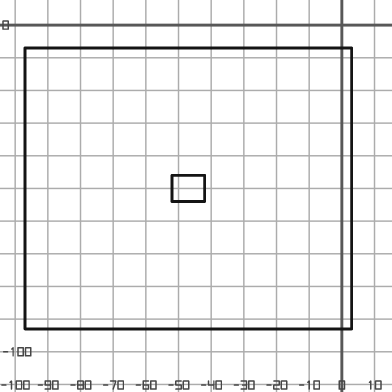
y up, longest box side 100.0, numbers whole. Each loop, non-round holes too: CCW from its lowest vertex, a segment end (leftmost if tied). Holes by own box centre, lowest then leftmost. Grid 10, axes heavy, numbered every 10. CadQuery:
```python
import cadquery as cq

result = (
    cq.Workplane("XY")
    .moveTo(-97.0, -93.0)
    .lineTo(3.0, -93.0)
    .lineTo(3.0, -7.0)
    .lineTo(-97.0, -7.0)
    .close()
    .moveTo(-52.0, -54.0)
    .lineTo(-42.0, -54.0)
    .lineTo(-42.0, -46.0)
    .lineTo(-52.0, -46.0)
    .close()
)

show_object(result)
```